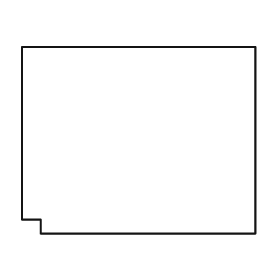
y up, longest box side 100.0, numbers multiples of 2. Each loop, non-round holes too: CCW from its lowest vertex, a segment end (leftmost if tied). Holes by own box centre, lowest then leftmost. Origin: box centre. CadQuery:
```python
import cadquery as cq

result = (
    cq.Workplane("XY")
    .moveTo(-42.0, -40.0)
    .lineTo(50.0, -40.0)
    .lineTo(50.0, 40.0)
    .lineTo(-50.0, 40.0)
    .lineTo(-50.0, -34.0)
    .lineTo(-42.0, -34.0)
    .close()
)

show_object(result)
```